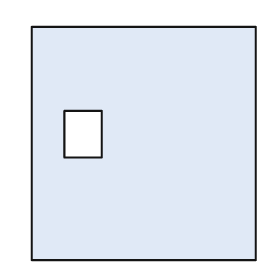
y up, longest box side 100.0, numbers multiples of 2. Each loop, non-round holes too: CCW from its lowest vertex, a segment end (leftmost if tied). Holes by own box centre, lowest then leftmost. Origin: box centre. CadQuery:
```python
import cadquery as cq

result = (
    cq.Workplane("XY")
    .moveTo(-48.0, -50.0)
    .lineTo(48.0, -50.0)
    .lineTo(48.0, 50.0)
    .lineTo(-48.0, 50.0)
    .close()
    .moveTo(-34.0, -6.0)
    .lineTo(-18.0, -6.0)
    .lineTo(-18.0, 14.0)
    .lineTo(-34.0, 14.0)
    .close()
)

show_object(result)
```